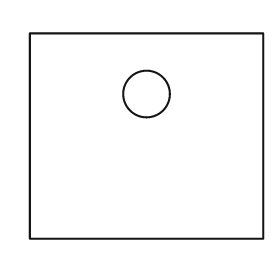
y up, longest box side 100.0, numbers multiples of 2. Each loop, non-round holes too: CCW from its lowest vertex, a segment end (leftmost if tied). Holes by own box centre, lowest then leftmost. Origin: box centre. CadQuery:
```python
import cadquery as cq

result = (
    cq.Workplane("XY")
    .moveTo(-50.0, -44.0)
    .lineTo(50.0, -44.0)
    .lineTo(50.0, 44.0)
    .lineTo(-50.0, 44.0)
    .close()
    .moveTo(0.0, 18.0)
    .circle(10.0)
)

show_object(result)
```